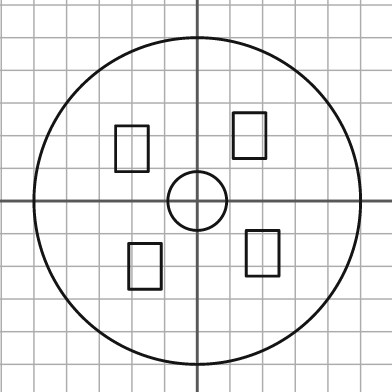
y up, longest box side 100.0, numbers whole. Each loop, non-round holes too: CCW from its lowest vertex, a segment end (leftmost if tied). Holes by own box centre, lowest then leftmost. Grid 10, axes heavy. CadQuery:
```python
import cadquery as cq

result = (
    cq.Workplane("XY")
    .moveTo(0.0, 0.0)
    .circle(50.0)
    .moveTo(-21.0, -27.0)
    .lineTo(-11.0, -27.0)
    .lineTo(-11.0, -13.0)
    .lineTo(-21.0, -13.0)
    .close()
    .moveTo(15.0, -23.0)
    .lineTo(25.0, -23.0)
    .lineTo(25.0, -9.0)
    .lineTo(15.0, -9.0)
    .close()
    .moveTo(0.0, 0.0)
    .circle(9.0)
    .moveTo(-25.0, 9.0)
    .lineTo(-15.0, 9.0)
    .lineTo(-15.0, 23.0)
    .lineTo(-25.0, 23.0)
    .close()
    .moveTo(11.0, 13.0)
    .lineTo(21.0, 13.0)
    .lineTo(21.0, 27.0)
    .lineTo(11.0, 27.0)
    .close()
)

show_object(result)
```